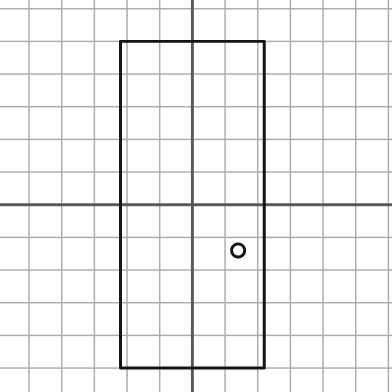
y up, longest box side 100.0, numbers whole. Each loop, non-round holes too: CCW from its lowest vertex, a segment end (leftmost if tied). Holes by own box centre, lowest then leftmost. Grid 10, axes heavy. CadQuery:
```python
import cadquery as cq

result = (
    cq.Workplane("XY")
    .moveTo(-22.0, -50.0)
    .lineTo(22.0, -50.0)
    .lineTo(22.0, 50.0)
    .lineTo(-22.0, 50.0)
    .close()
    .moveTo(14.0, -14.0)
    .circle(2.0)
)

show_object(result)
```